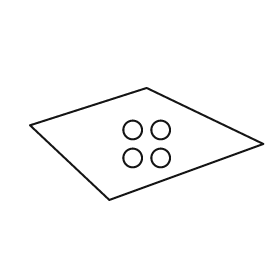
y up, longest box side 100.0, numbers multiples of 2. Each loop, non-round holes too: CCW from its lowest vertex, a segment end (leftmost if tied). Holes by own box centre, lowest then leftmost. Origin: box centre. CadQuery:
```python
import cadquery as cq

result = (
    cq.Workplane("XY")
    .moveTo(-16.0, -24.0)
    .lineTo(50.0, 0.0)
    .lineTo(0.0, 24.0)
    .lineTo(-50.0, 8.0)
    .close()
    .moveTo(-6.0, -6.0)
    .circle(4.0)
    .moveTo(6.0, -6.0)
    .circle(4.0)
    .moveTo(-6.0, 6.0)
    .circle(4.0)
    .moveTo(6.0, 6.0)
    .circle(4.0)
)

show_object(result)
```